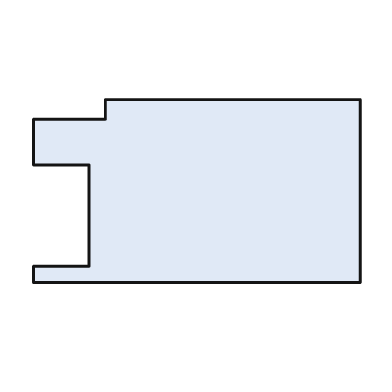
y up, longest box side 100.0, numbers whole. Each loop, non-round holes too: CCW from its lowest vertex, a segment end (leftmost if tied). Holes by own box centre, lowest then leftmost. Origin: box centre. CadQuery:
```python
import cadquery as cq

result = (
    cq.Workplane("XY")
    .moveTo(-50.0, -28.0)
    .lineTo(50.0, -28.0)
    .lineTo(50.0, 28.0)
    .lineTo(-28.0, 28.0)
    .lineTo(-28.0, 22.0)
    .lineTo(-50.0, 22.0)
    .lineTo(-50.0, 8.0)
    .lineTo(-33.0, 8.0)
    .lineTo(-33.0, -23.0)
    .lineTo(-50.0, -23.0)
    .close()
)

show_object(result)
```